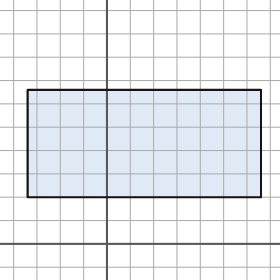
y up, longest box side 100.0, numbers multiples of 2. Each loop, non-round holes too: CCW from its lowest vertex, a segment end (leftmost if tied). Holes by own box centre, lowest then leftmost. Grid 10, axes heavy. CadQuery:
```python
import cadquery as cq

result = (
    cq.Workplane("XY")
    .moveTo(-34.0, 20.0)
    .lineTo(66.0, 20.0)
    .lineTo(66.0, 66.0)
    .lineTo(-34.0, 66.0)
    .close()
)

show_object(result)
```